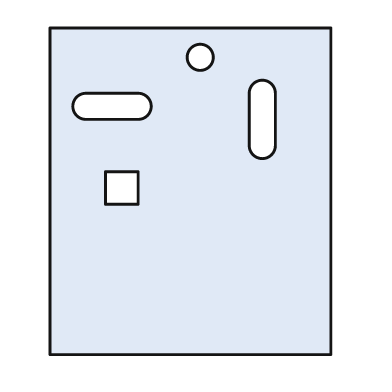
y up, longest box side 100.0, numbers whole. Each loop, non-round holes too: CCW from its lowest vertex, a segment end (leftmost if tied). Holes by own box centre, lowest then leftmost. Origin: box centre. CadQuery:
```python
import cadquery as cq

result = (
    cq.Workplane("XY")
    .moveTo(-43.0, -50.0)
    .lineTo(43.0, -50.0)
    .lineTo(43.0, 50.0)
    .lineTo(-43.0, 50.0)
    .close()
    .moveTo(-26.0, -4.0)
    .lineTo(-16.0, -4.0)
    .lineTo(-16.0, 6.0)
    .lineTo(-26.0, 6.0)
    .close()
    .moveTo(18.0, 14.0)
    .threePointArc((22.0, 10.0), (26.0, 14.0))
    .lineTo(26.0, 30.0)
    .threePointArc((22.0, 34.0), (18.0, 30.0))
    .close()
    .moveTo(-32.0, 22.0)
    .lineTo(-16.0, 22.0)
    .threePointArc((-12.0, 26.0), (-16.0, 30.0))
    .lineTo(-32.0, 30.0)
    .threePointArc((-36.0, 26.0), (-32.0, 22.0))
    .close()
    .moveTo(3.0, 41.0)
    .circle(4.0)
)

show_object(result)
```